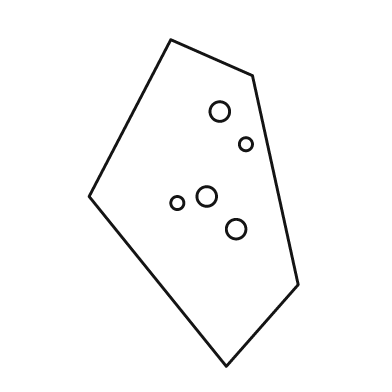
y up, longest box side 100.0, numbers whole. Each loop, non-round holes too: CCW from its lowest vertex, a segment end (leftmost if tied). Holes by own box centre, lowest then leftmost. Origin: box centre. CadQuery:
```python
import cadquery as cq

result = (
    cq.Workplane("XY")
    .moveTo(10.0, -50.0)
    .lineTo(32.0, -25.0)
    .lineTo(18.0, 39.0)
    .lineTo(-7.0, 50.0)
    .lineTo(-32.0, 2.0)
    .close()
    .moveTo(13.0, -8.0)
    .circle(3.0)
    .moveTo(-5.0, 0.0)
    .circle(2.0)
    .moveTo(4.0, 2.0)
    .circle(3.0)
    .moveTo(16.0, 18.0)
    .circle(2.0)
    .moveTo(8.0, 28.0)
    .circle(3.0)
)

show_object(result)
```